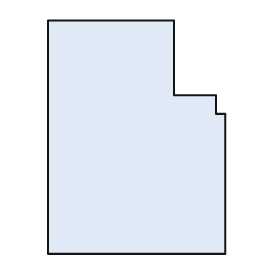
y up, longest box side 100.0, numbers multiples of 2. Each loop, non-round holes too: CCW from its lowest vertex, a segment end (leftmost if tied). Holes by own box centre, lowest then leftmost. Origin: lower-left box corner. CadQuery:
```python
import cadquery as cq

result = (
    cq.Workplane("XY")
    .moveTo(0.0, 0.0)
    .lineTo(76.0, 0.0)
    .lineTo(76.0, 60.0)
    .lineTo(72.0, 60.0)
    .lineTo(72.0, 68.0)
    .lineTo(54.0, 68.0)
    .lineTo(54.0, 100.0)
    .lineTo(0.0, 100.0)
    .close()
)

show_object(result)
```